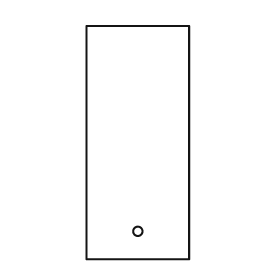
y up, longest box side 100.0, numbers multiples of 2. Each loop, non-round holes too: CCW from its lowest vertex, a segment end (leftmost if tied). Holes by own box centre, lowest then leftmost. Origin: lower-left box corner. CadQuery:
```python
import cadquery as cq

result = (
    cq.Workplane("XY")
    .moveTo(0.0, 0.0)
    .lineTo(44.0, 0.0)
    .lineTo(44.0, 100.0)
    .lineTo(0.0, 100.0)
    .close()
    .moveTo(22.0, 12.0)
    .circle(2.0)
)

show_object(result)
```